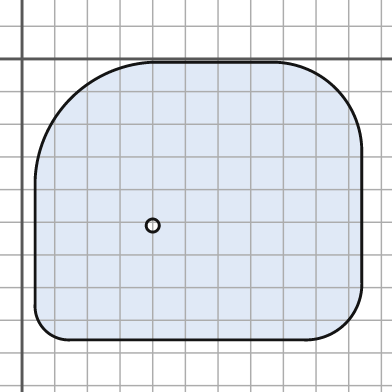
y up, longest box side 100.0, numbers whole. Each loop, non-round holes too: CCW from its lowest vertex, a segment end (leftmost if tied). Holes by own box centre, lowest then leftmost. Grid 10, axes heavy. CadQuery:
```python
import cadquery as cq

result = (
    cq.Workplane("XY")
    .moveTo(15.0, -86.0)
    .lineTo(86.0, -86.0)
    .threePointArc((99.0, -81.0), (104.0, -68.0))
    .lineTo(104.0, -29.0)
    .threePointArc((96.0, -9.0), (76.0, -1.0))
    .lineTo(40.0, -1.0)
    .threePointArc((15.0, -12.0), (4.0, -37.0))
    .lineTo(4.0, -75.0)
    .threePointArc((7.0, -83.0), (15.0, -86.0))
    .close()
    .moveTo(40.0, -51.0)
    .circle(2.0)
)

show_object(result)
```